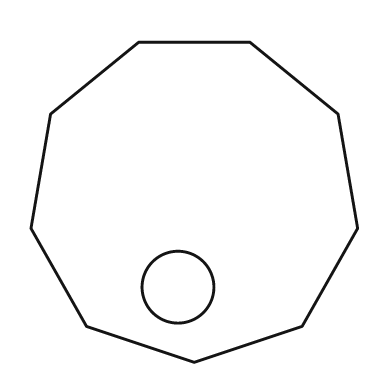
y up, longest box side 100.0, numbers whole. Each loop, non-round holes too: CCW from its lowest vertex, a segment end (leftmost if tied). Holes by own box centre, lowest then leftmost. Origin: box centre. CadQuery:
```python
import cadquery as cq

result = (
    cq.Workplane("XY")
    .moveTo(0.0, -49.0)
    .lineTo(33.0, -38.0)
    .lineTo(50.0, -8.0)
    .lineTo(44.0, 27.0)
    .lineTo(17.0, 49.0)
    .lineTo(-17.0, 49.0)
    .lineTo(-44.0, 27.0)
    .lineTo(-50.0, -8.0)
    .lineTo(-33.0, -38.0)
    .close()
    .moveTo(-5.0, -26.0)
    .circle(11.0)
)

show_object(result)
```